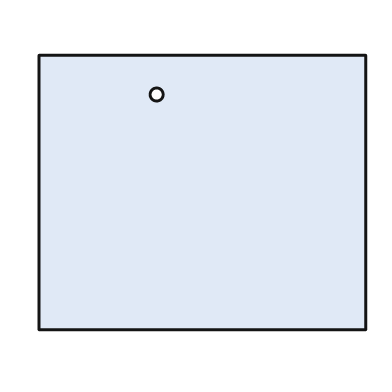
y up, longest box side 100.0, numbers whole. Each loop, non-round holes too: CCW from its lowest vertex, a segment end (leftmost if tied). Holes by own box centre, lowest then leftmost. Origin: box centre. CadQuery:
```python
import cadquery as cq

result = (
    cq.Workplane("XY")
    .moveTo(-50.0, -42.0)
    .lineTo(50.0, -42.0)
    .lineTo(50.0, 42.0)
    .lineTo(-50.0, 42.0)
    .close()
    .moveTo(-14.0, 30.0)
    .circle(2.0)
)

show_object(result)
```